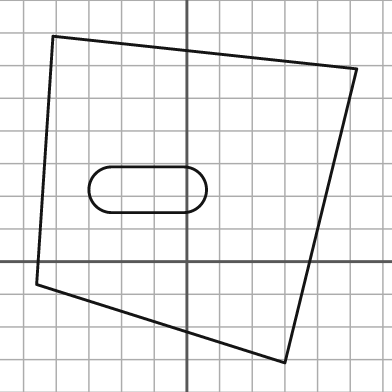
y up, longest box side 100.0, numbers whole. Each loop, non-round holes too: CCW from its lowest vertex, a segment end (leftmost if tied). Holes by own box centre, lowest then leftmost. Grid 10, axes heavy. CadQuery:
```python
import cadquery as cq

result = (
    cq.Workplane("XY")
    .moveTo(30.0, -31.0)
    .lineTo(52.0, 59.0)
    .lineTo(-41.0, 69.0)
    .lineTo(-46.0, -7.0)
    .close()
    .moveTo(-23.0, 15.0)
    .lineTo(-1.0, 15.0)
    .threePointArc((6.0, 22.0), (-1.0, 29.0))
    .lineTo(-23.0, 29.0)
    .threePointArc((-30.0, 22.0), (-23.0, 15.0))
    .close()
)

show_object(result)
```